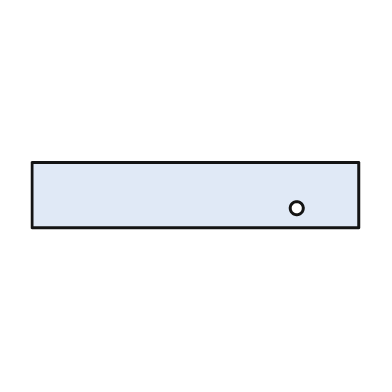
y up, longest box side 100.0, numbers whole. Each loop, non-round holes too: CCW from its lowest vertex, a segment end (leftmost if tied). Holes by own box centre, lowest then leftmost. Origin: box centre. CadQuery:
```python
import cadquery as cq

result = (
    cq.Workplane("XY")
    .moveTo(-50.0, -10.0)
    .lineTo(50.0, -10.0)
    .lineTo(50.0, 10.0)
    .lineTo(-50.0, 10.0)
    .close()
    .moveTo(31.0, -4.0)
    .circle(2.0)
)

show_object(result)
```